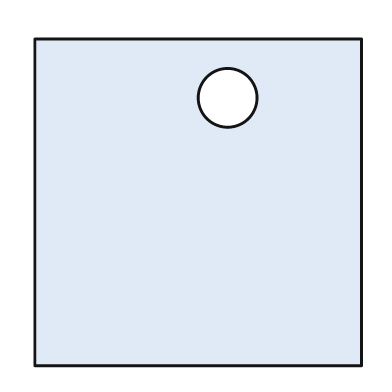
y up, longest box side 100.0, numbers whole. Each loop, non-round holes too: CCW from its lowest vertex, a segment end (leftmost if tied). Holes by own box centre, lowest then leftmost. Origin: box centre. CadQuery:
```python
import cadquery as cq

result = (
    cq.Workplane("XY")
    .moveTo(-50.0, -50.0)
    .lineTo(50.0, -50.0)
    .lineTo(50.0, 50.0)
    .lineTo(-50.0, 50.0)
    .close()
    .moveTo(9.0, 32.0)
    .circle(9.0)
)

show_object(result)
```